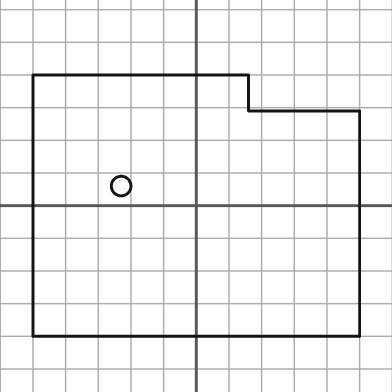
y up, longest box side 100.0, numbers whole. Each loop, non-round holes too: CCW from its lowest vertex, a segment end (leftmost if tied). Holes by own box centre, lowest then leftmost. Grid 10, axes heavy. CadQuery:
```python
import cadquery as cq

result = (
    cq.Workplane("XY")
    .moveTo(-50.0, -40.0)
    .lineTo(50.0, -40.0)
    .lineTo(50.0, 29.0)
    .lineTo(16.0, 29.0)
    .lineTo(16.0, 40.0)
    .lineTo(-50.0, 40.0)
    .close()
    .moveTo(-23.0, 6.0)
    .circle(3.0)
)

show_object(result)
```